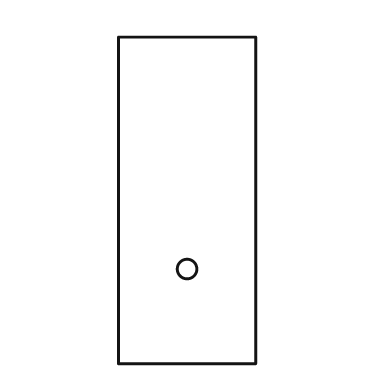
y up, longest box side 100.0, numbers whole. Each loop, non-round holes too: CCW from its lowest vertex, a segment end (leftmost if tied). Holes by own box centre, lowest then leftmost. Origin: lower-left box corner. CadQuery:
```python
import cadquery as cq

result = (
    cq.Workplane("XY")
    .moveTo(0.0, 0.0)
    .lineTo(42.0, 0.0)
    .lineTo(42.0, 100.0)
    .lineTo(0.0, 100.0)
    .close()
    .moveTo(21.0, 29.0)
    .circle(3.0)
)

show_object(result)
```